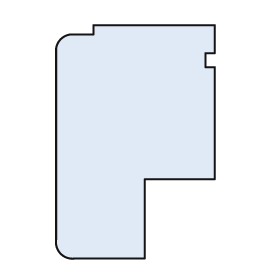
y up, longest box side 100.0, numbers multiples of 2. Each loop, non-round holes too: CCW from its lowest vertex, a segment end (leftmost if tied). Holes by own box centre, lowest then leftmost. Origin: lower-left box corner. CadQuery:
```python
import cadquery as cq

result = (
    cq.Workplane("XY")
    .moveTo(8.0, 0.0)
    .lineTo(38.0, 0.0)
    .lineTo(38.0, 34.0)
    .lineTo(68.0, 34.0)
    .lineTo(68.0, 82.0)
    .lineTo(64.0, 82.0)
    .lineTo(64.0, 88.0)
    .lineTo(68.0, 88.0)
    .lineTo(68.0, 100.0)
    .lineTo(16.0, 100.0)
    .lineTo(16.0, 96.0)
    .lineTo(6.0, 96.0)
    .threePointArc((2.0, 94.0), (0.0, 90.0))
    .lineTo(0.0, 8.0)
    .threePointArc((2.0, 2.0), (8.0, 0.0))
    .close()
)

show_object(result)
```